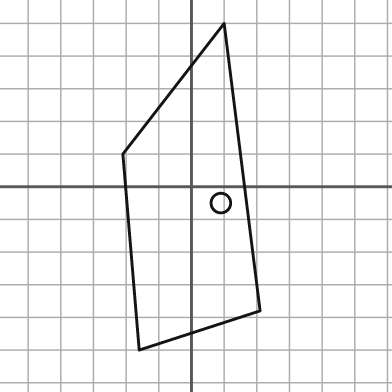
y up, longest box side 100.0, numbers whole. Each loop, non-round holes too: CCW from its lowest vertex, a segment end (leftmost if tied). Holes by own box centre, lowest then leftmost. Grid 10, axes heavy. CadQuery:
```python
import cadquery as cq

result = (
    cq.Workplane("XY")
    .moveTo(-16.0, -50.0)
    .lineTo(21.0, -38.0)
    .lineTo(10.0, 50.0)
    .lineTo(-21.0, 10.0)
    .close()
    .moveTo(9.0, -5.0)
    .circle(3.0)
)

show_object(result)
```